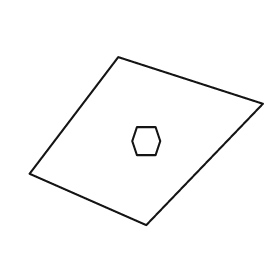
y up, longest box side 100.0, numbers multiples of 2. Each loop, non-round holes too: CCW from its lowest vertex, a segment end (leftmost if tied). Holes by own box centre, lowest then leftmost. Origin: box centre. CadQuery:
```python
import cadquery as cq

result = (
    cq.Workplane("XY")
    .moveTo(0.0, -36.0)
    .lineTo(50.0, 16.0)
    .lineTo(-12.0, 36.0)
    .lineTo(-50.0, -14.0)
    .close()
    .moveTo(-4.0, -6.0)
    .lineTo(4.0, -6.0)
    .lineTo(6.0, 0.0)
    .lineTo(4.0, 6.0)
    .lineTo(-4.0, 6.0)
    .lineTo(-6.0, 0.0)
    .close()
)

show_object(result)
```